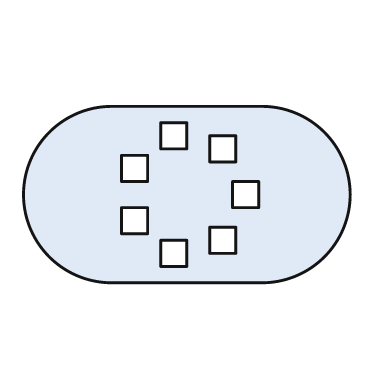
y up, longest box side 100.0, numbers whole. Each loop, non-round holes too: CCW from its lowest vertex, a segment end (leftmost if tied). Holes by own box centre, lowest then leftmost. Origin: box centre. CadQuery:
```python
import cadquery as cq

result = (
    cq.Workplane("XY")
    .moveTo(-23.0, -27.0)
    .lineTo(23.0, -27.0)
    .threePointArc((50.0, 0.0), (23.0, 27.0))
    .lineTo(-23.0, 27.0)
    .threePointArc((-50.0, 0.0), (-23.0, -27.0))
    .close()
    .moveTo(-8.0, -22.0)
    .lineTo(0.0, -22.0)
    .lineTo(0.0, -14.0)
    .lineTo(-8.0, -14.0)
    .close()
    .moveTo(7.0, -18.0)
    .lineTo(15.0, -18.0)
    .lineTo(15.0, -10.0)
    .lineTo(7.0, -10.0)
    .close()
    .moveTo(-20.0, -12.0)
    .lineTo(-12.0, -12.0)
    .lineTo(-12.0, -4.0)
    .lineTo(-20.0, -4.0)
    .close()
    .moveTo(14.0, -4.0)
    .lineTo(22.0, -4.0)
    .lineTo(22.0, 4.0)
    .lineTo(14.0, 4.0)
    .close()
    .moveTo(-20.0, 4.0)
    .lineTo(-12.0, 4.0)
    .lineTo(-12.0, 12.0)
    .lineTo(-20.0, 12.0)
    .close()
    .moveTo(7.0, 10.0)
    .lineTo(15.0, 10.0)
    .lineTo(15.0, 18.0)
    .lineTo(7.0, 18.0)
    .close()
    .moveTo(-8.0, 14.0)
    .lineTo(0.0, 14.0)
    .lineTo(0.0, 22.0)
    .lineTo(-8.0, 22.0)
    .close()
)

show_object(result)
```